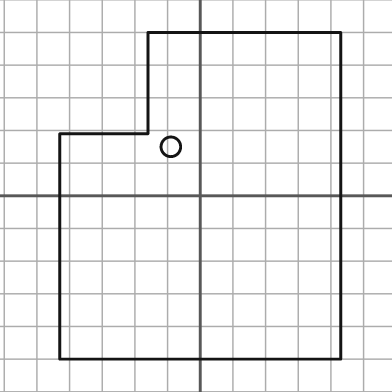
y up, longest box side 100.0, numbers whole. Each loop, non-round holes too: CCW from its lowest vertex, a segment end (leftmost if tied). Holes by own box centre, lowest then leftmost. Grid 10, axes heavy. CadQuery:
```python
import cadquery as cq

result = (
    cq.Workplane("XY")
    .moveTo(-43.0, -50.0)
    .lineTo(43.0, -50.0)
    .lineTo(43.0, 50.0)
    .lineTo(-16.0, 50.0)
    .lineTo(-16.0, 19.0)
    .lineTo(-43.0, 19.0)
    .close()
    .moveTo(-9.0, 15.0)
    .circle(3.0)
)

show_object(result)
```